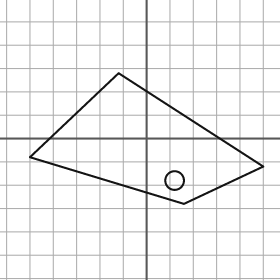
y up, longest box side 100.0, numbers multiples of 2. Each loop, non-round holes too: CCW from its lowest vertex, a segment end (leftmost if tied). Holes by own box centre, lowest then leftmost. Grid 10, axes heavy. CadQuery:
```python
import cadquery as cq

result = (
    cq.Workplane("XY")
    .moveTo(16.0, -28.0)
    .lineTo(50.0, -12.0)
    .lineTo(-12.0, 28.0)
    .lineTo(-50.0, -8.0)
    .close()
    .moveTo(12.0, -18.0)
    .circle(4.0)
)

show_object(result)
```